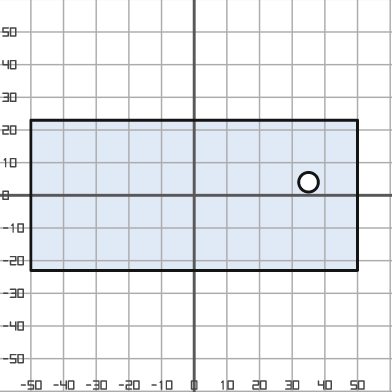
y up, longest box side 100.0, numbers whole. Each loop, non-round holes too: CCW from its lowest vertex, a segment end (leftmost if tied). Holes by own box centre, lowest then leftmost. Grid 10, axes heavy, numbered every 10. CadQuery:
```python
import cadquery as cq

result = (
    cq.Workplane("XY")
    .moveTo(-50.0, -23.0)
    .lineTo(50.0, -23.0)
    .lineTo(50.0, 23.0)
    .lineTo(-50.0, 23.0)
    .close()
    .moveTo(35.0, 4.0)
    .circle(3.0)
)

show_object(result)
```